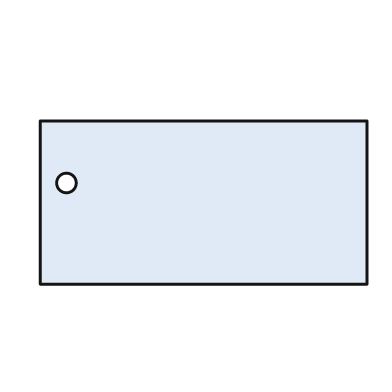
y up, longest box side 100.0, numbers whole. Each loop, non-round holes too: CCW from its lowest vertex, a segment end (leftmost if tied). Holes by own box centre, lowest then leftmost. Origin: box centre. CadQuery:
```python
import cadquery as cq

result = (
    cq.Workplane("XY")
    .moveTo(-50.0, -25.0)
    .lineTo(50.0, -25.0)
    .lineTo(50.0, 25.0)
    .lineTo(-50.0, 25.0)
    .close()
    .moveTo(-42.0, 6.0)
    .circle(3.0)
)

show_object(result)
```